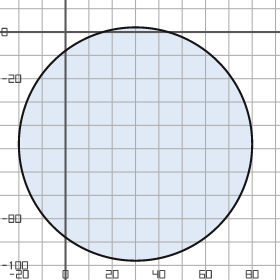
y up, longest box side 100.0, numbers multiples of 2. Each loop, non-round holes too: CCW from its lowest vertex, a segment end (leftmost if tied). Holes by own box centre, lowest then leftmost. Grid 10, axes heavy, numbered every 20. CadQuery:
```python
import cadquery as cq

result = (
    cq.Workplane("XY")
    .moveTo(30.0, -48.0)
    .circle(50.0)
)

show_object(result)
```